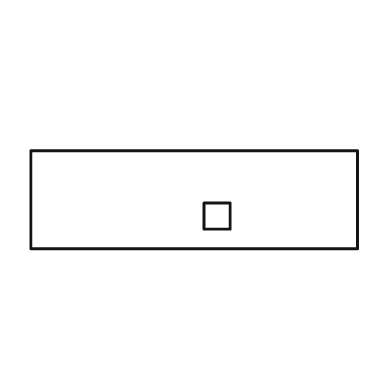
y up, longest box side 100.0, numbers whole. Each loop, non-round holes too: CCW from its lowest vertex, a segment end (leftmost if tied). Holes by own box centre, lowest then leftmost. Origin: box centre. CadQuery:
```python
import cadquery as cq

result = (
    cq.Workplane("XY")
    .moveTo(-50.0, -15.0)
    .lineTo(50.0, -15.0)
    .lineTo(50.0, 15.0)
    .lineTo(-50.0, 15.0)
    .close()
    .moveTo(3.0, -9.0)
    .lineTo(11.0, -9.0)
    .lineTo(11.0, -1.0)
    .lineTo(3.0, -1.0)
    .close()
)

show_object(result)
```